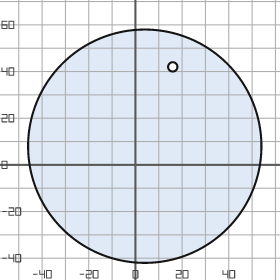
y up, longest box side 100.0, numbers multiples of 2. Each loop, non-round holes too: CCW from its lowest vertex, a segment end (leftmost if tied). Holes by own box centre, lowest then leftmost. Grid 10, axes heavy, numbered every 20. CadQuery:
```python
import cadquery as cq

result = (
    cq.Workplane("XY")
    .moveTo(4.0, 8.0)
    .circle(50.0)
    .moveTo(16.0, 42.0)
    .circle(2.0)
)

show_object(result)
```